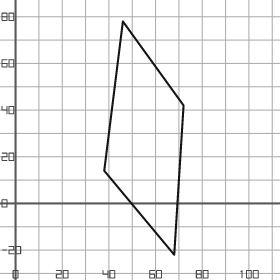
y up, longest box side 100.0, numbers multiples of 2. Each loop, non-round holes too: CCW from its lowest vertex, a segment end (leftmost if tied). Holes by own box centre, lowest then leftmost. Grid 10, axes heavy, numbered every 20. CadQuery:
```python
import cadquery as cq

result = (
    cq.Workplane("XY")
    .moveTo(68.0, -22.0)
    .lineTo(72.0, 42.0)
    .lineTo(46.0, 78.0)
    .lineTo(38.0, 14.0)
    .close()
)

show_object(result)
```